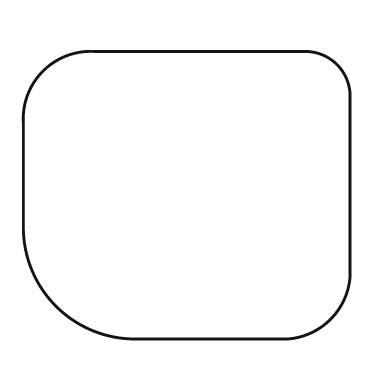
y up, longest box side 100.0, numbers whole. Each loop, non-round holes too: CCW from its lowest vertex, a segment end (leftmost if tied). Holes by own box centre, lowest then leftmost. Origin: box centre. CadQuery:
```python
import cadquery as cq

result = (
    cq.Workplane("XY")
    .moveTo(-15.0, -44.0)
    .lineTo(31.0, -44.0)
    .threePointArc((44.0, -38.0), (50.0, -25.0))
    .lineTo(50.0, 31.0)
    .threePointArc((46.0, 40.0), (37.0, 44.0))
    .lineTo(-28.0, 44.0)
    .threePointArc((-44.0, 38.0), (-50.0, 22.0))
    .lineTo(-50.0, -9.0)
    .threePointArc((-40.0, -34.0), (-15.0, -44.0))
    .close()
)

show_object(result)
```